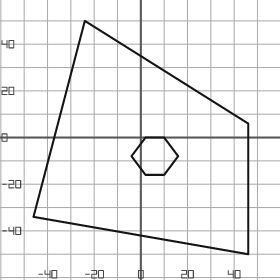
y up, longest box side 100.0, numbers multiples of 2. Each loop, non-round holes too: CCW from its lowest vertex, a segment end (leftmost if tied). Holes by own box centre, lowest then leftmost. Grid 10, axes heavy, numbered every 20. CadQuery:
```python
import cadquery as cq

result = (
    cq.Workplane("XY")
    .moveTo(46.0, -50.0)
    .lineTo(46.0, 6.0)
    .lineTo(-24.0, 50.0)
    .lineTo(-46.0, -34.0)
    .close()
    .moveTo(2.0, -16.0)
    .lineTo(10.0, -16.0)
    .lineTo(16.0, -8.0)
    .lineTo(10.0, 0.0)
    .lineTo(2.0, 0.0)
    .lineTo(-4.0, -8.0)
    .close()
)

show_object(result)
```